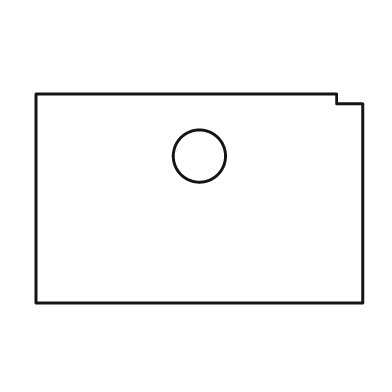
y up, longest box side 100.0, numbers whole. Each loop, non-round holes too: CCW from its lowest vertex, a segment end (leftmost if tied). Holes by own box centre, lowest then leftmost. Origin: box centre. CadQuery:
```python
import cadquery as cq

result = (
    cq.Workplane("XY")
    .moveTo(-50.0, -32.0)
    .lineTo(50.0, -32.0)
    .lineTo(50.0, 29.0)
    .lineTo(42.0, 29.0)
    .lineTo(42.0, 32.0)
    .lineTo(-50.0, 32.0)
    .close()
    .moveTo(0.0, 13.0)
    .circle(8.0)
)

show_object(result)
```